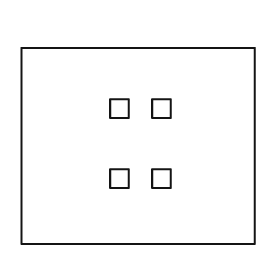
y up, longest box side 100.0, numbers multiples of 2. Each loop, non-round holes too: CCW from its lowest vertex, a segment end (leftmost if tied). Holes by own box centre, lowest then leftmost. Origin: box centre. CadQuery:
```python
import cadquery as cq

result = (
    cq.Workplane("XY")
    .moveTo(-50.0, -42.0)
    .lineTo(50.0, -42.0)
    .lineTo(50.0, 42.0)
    .lineTo(-50.0, 42.0)
    .close()
    .moveTo(-12.0, -18.0)
    .lineTo(-4.0, -18.0)
    .lineTo(-4.0, -10.0)
    .lineTo(-12.0, -10.0)
    .close()
    .moveTo(6.0, -18.0)
    .lineTo(14.0, -18.0)
    .lineTo(14.0, -10.0)
    .lineTo(6.0, -10.0)
    .close()
    .moveTo(-12.0, 12.0)
    .lineTo(-4.0, 12.0)
    .lineTo(-4.0, 20.0)
    .lineTo(-12.0, 20.0)
    .close()
    .moveTo(6.0, 12.0)
    .lineTo(14.0, 12.0)
    .lineTo(14.0, 20.0)
    .lineTo(6.0, 20.0)
    .close()
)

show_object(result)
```